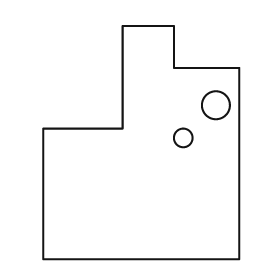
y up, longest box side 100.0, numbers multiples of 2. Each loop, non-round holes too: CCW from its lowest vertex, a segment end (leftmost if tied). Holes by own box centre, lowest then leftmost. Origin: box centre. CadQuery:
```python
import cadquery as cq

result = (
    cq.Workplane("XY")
    .moveTo(-42.0, -50.0)
    .lineTo(42.0, -50.0)
    .lineTo(42.0, 32.0)
    .lineTo(14.0, 32.0)
    .lineTo(14.0, 50.0)
    .lineTo(-8.0, 50.0)
    .lineTo(-8.0, 6.0)
    .lineTo(-42.0, 6.0)
    .close()
    .moveTo(18.0, 2.0)
    .circle(4.0)
    .moveTo(32.0, 16.0)
    .circle(6.0)
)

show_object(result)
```